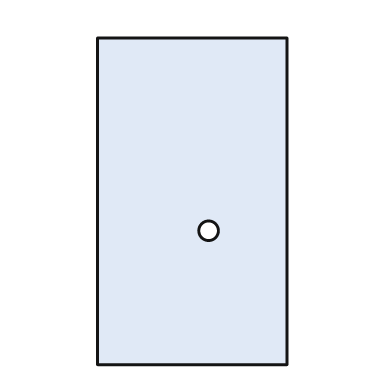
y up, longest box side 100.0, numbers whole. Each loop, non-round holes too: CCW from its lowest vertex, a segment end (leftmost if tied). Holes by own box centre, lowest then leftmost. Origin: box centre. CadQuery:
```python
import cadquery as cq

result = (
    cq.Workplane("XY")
    .moveTo(-29.0, -50.0)
    .lineTo(29.0, -50.0)
    .lineTo(29.0, 50.0)
    .lineTo(-29.0, 50.0)
    .close()
    .moveTo(5.0, -9.0)
    .circle(3.0)
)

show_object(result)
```